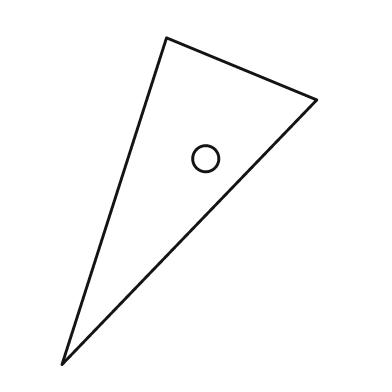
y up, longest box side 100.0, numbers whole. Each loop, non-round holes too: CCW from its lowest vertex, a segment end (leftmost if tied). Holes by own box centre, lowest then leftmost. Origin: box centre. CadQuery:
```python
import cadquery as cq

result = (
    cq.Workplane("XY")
    .moveTo(-39.0, -50.0)
    .lineTo(39.0, 31.0)
    .lineTo(-7.0, 50.0)
    .close()
    .moveTo(5.0, 13.0)
    .circle(4.0)
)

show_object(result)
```